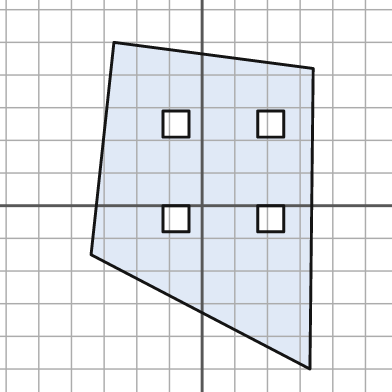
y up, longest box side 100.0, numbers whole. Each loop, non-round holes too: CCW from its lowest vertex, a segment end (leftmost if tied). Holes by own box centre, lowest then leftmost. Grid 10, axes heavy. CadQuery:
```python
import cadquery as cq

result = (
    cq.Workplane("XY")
    .moveTo(33.0, -50.0)
    .lineTo(34.0, 42.0)
    .lineTo(-27.0, 50.0)
    .lineTo(-34.0, -15.0)
    .close()
    .moveTo(-12.0, -8.0)
    .lineTo(-4.0, -8.0)
    .lineTo(-4.0, 0.0)
    .lineTo(-12.0, 0.0)
    .close()
    .moveTo(17.0, -8.0)
    .lineTo(25.0, -8.0)
    .lineTo(25.0, 0.0)
    .lineTo(17.0, 0.0)
    .close()
    .moveTo(-12.0, 21.0)
    .lineTo(-4.0, 21.0)
    .lineTo(-4.0, 29.0)
    .lineTo(-12.0, 29.0)
    .close()
    .moveTo(17.0, 21.0)
    .lineTo(25.0, 21.0)
    .lineTo(25.0, 29.0)
    .lineTo(17.0, 29.0)
    .close()
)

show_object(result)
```